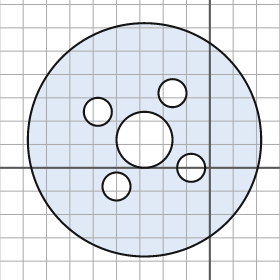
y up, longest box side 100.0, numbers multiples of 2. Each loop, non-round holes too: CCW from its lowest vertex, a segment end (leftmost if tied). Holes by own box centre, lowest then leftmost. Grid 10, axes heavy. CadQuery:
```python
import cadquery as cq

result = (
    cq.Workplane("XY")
    .moveTo(-28.0, 12.0)
    .circle(50.0)
    .moveTo(-40.0, -8.0)
    .circle(6.0)
    .moveTo(-8.0, 0.0)
    .circle(6.0)
    .moveTo(-28.0, 12.0)
    .circle(12.0)
    .moveTo(-48.0, 24.0)
    .circle(6.0)
    .moveTo(-16.0, 32.0)
    .circle(6.0)
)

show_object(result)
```